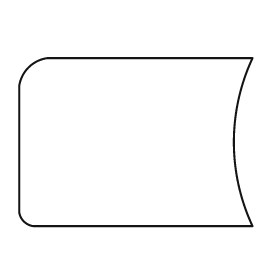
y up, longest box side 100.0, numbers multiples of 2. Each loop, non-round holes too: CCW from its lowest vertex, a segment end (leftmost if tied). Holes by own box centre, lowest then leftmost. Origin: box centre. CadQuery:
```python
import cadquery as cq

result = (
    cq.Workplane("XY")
    .moveTo(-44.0, -36.0)
    .lineTo(50.0, -36.0)
    .threePointArc((42.0, 0.0), (50.0, 36.0))
    .lineTo(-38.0, 36.0)
    .threePointArc((-46.0, 32.0), (-50.0, 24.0))
    .lineTo(-50.0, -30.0)
    .threePointArc((-48.0, -34.0), (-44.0, -36.0))
    .close()
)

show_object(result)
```